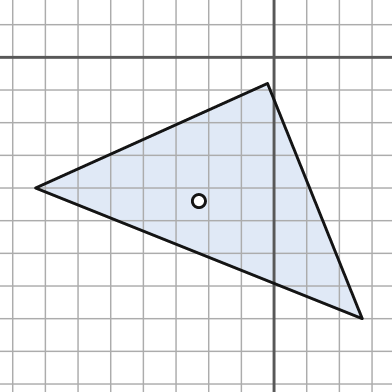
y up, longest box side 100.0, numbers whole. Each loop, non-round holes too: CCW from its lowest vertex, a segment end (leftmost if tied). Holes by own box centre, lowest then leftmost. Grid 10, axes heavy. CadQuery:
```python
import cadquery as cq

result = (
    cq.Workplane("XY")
    .moveTo(27.0, -80.0)
    .lineTo(-2.0, -8.0)
    .lineTo(-73.0, -40.0)
    .close()
    .moveTo(-23.0, -44.0)
    .circle(2.0)
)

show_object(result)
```